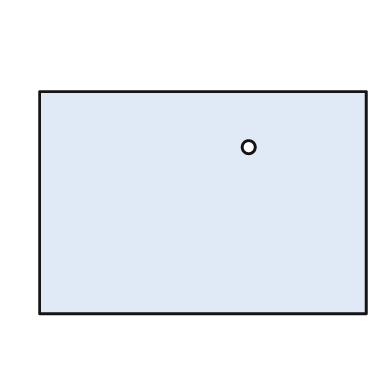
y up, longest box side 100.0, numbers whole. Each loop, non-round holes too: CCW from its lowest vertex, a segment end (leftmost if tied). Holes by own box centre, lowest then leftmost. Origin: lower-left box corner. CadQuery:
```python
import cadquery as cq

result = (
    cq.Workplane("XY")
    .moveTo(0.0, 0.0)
    .lineTo(100.0, 0.0)
    .lineTo(100.0, 68.0)
    .lineTo(0.0, 68.0)
    .close()
    .moveTo(64.0, 51.0)
    .circle(2.0)
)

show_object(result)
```